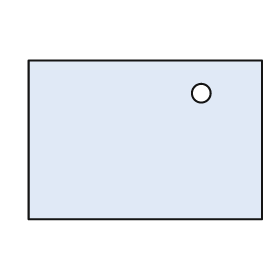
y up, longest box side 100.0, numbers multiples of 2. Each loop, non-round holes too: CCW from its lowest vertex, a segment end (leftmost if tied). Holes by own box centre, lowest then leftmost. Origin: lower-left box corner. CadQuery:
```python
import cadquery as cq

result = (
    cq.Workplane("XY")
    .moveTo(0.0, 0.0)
    .lineTo(100.0, 0.0)
    .lineTo(100.0, 68.0)
    .lineTo(0.0, 68.0)
    .close()
    .moveTo(74.0, 54.0)
    .circle(4.0)
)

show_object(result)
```